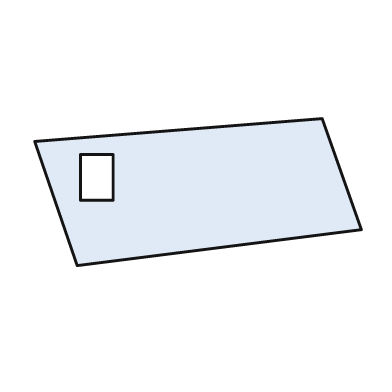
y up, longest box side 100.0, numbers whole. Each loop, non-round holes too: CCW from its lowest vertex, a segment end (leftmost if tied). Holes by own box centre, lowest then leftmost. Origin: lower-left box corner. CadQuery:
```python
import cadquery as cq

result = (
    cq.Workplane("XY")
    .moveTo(13.0, 0.0)
    .lineTo(100.0, 11.0)
    .lineTo(88.0, 45.0)
    .lineTo(0.0, 38.0)
    .close()
    .moveTo(14.0, 20.0)
    .lineTo(24.0, 20.0)
    .lineTo(24.0, 34.0)
    .lineTo(14.0, 34.0)
    .close()
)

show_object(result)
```